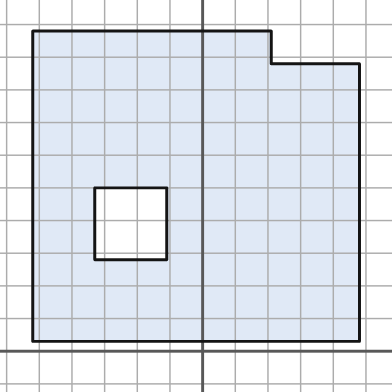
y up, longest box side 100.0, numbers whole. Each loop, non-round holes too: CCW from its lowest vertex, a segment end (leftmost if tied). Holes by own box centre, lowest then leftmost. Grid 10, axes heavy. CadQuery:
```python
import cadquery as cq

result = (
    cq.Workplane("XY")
    .moveTo(-52.0, 3.0)
    .lineTo(48.0, 3.0)
    .lineTo(48.0, 88.0)
    .lineTo(21.0, 88.0)
    .lineTo(21.0, 98.0)
    .lineTo(-52.0, 98.0)
    .close()
    .moveTo(-33.0, 28.0)
    .lineTo(-11.0, 28.0)
    .lineTo(-11.0, 50.0)
    .lineTo(-33.0, 50.0)
    .close()
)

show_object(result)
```